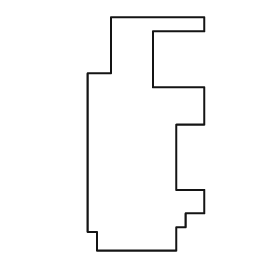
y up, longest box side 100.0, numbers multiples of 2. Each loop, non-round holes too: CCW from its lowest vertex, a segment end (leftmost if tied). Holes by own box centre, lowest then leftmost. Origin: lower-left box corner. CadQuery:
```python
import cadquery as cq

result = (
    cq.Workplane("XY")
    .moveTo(4.0, 0.0)
    .lineTo(38.0, 0.0)
    .lineTo(38.0, 10.0)
    .lineTo(42.0, 10.0)
    .lineTo(42.0, 16.0)
    .lineTo(50.0, 16.0)
    .lineTo(50.0, 26.0)
    .lineTo(38.0, 26.0)
    .lineTo(38.0, 54.0)
    .lineTo(50.0, 54.0)
    .lineTo(50.0, 70.0)
    .lineTo(28.0, 70.0)
    .lineTo(28.0, 94.0)
    .lineTo(50.0, 94.0)
    .lineTo(50.0, 100.0)
    .lineTo(10.0, 100.0)
    .lineTo(10.0, 76.0)
    .lineTo(0.0, 76.0)
    .lineTo(0.0, 8.0)
    .lineTo(4.0, 8.0)
    .close()
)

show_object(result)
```